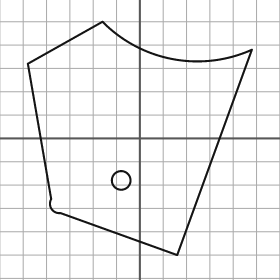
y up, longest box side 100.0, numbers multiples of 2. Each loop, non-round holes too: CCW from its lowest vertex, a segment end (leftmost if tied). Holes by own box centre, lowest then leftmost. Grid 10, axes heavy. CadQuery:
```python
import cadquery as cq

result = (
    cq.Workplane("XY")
    .moveTo(16.0, -50.0)
    .lineTo(48.0, 38.0)
    .threePointArc((14.0, 34.0), (-16.0, 50.0))
    .lineTo(-48.0, 32.0)
    .lineTo(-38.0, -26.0)
    .threePointArc((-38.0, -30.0), (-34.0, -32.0))
    .close()
    .moveTo(-8.0, -18.0)
    .circle(4.0)
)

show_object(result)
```